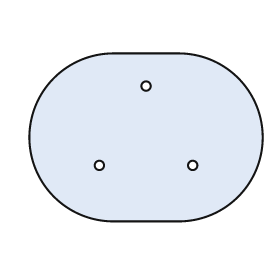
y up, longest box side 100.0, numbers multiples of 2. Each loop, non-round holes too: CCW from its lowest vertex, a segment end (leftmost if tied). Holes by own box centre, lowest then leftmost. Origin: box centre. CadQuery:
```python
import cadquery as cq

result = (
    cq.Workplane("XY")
    .moveTo(-14.0, -36.0)
    .lineTo(14.0, -36.0)
    .threePointArc((50.0, 0.0), (14.0, 36.0))
    .lineTo(-14.0, 36.0)
    .threePointArc((-50.0, 0.0), (-14.0, -36.0))
    .close()
    .moveTo(-20.0, -12.0)
    .circle(2.0)
    .moveTo(20.0, -12.0)
    .circle(2.0)
    .moveTo(0.0, 22.0)
    .circle(2.0)
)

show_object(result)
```